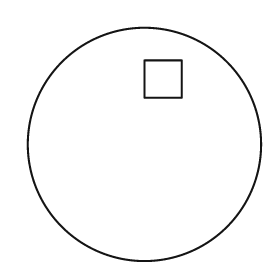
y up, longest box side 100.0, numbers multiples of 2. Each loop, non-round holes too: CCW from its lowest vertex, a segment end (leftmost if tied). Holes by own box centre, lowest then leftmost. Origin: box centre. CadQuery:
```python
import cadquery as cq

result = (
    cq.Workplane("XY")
    .moveTo(0.0, 0.0)
    .circle(50.0)
    .moveTo(0.0, 20.0)
    .lineTo(16.0, 20.0)
    .lineTo(16.0, 36.0)
    .lineTo(0.0, 36.0)
    .close()
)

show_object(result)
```